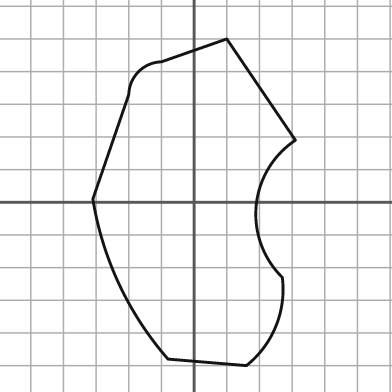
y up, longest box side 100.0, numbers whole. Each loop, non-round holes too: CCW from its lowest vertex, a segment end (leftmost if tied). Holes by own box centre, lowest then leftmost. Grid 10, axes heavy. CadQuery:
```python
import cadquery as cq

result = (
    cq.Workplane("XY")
    .moveTo(16.0, -50.0)
    .threePointArc((25.0, -38.0), (27.0, -23.0))
    .threePointArc((19.0, -1.0), (31.0, 19.0))
    .lineTo(10.0, 50.0)
    .lineTo(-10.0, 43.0)
    .threePointArc((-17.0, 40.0), (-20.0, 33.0))
    .lineTo(-31.0, 1.0)
    .threePointArc((-23.0, -25.0), (-8.0, -48.0))
    .close()
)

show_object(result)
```